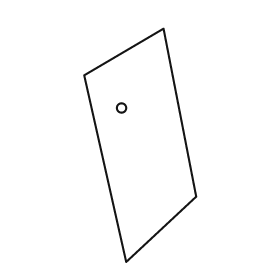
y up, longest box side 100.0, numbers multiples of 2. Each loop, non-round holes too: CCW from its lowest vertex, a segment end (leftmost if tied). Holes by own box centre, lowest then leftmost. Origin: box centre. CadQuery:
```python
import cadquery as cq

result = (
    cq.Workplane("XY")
    .moveTo(-6.0, -50.0)
    .lineTo(24.0, -22.0)
    .lineTo(10.0, 50.0)
    .lineTo(-24.0, 30.0)
    .close()
    .moveTo(-8.0, 16.0)
    .circle(2.0)
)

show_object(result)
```